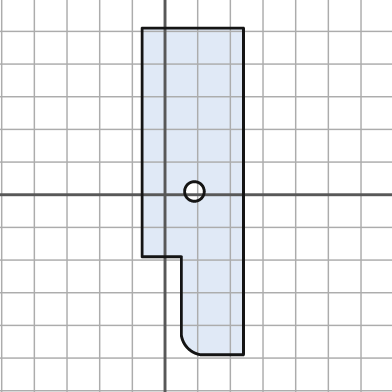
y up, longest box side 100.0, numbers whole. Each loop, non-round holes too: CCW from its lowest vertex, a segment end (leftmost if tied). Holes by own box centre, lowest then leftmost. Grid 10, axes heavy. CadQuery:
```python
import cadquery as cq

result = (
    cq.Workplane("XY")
    .moveTo(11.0, -49.0)
    .lineTo(24.0, -49.0)
    .lineTo(24.0, 51.0)
    .lineTo(-7.0, 51.0)
    .lineTo(-7.0, -19.0)
    .lineTo(5.0, -19.0)
    .lineTo(5.0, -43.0)
    .threePointArc((7.0, -47.0), (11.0, -49.0))
    .close()
    .moveTo(9.0, 1.0)
    .circle(3.0)
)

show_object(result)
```